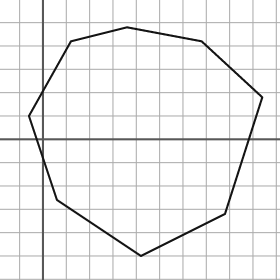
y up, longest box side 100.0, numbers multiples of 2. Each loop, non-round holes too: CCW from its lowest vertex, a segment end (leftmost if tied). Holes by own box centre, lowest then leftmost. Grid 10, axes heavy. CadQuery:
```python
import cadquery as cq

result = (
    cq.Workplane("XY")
    .moveTo(42.0, -50.0)
    .lineTo(78.0, -32.0)
    .lineTo(94.0, 18.0)
    .lineTo(68.0, 42.0)
    .lineTo(36.0, 48.0)
    .lineTo(12.0, 42.0)
    .lineTo(-6.0, 10.0)
    .lineTo(6.0, -26.0)
    .close()
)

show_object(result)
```